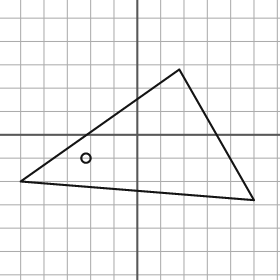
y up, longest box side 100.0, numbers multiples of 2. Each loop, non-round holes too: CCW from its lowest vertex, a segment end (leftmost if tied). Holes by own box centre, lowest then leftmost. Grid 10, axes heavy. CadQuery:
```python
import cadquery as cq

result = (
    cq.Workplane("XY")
    .moveTo(50.0, -28.0)
    .lineTo(18.0, 28.0)
    .lineTo(-50.0, -20.0)
    .close()
    .moveTo(-22.0, -10.0)
    .circle(2.0)
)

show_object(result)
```